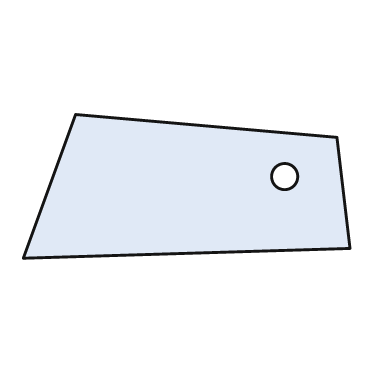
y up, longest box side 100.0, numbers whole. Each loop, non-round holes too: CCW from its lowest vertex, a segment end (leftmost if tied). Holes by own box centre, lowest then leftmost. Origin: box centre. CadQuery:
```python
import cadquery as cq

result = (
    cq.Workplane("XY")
    .moveTo(-50.0, -22.0)
    .lineTo(50.0, -19.0)
    .lineTo(46.0, 15.0)
    .lineTo(-34.0, 22.0)
    .close()
    .moveTo(30.0, 3.0)
    .circle(4.0)
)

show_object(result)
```